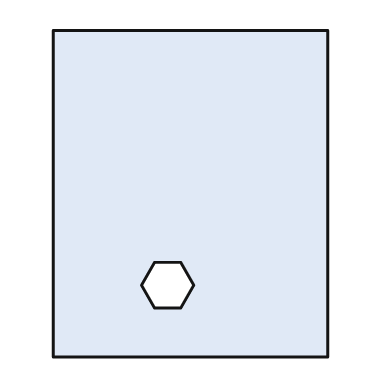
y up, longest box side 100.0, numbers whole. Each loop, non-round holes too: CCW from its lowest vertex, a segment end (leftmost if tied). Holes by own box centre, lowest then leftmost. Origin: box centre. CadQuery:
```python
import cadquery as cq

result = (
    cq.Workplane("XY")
    .moveTo(-42.0, -50.0)
    .lineTo(42.0, -50.0)
    .lineTo(42.0, 50.0)
    .lineTo(-42.0, 50.0)
    .close()
    .moveTo(-11.0, -35.0)
    .lineTo(-3.0, -35.0)
    .lineTo(1.0, -28.0)
    .lineTo(-3.0, -21.0)
    .lineTo(-11.0, -21.0)
    .lineTo(-15.0, -28.0)
    .close()
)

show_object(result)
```